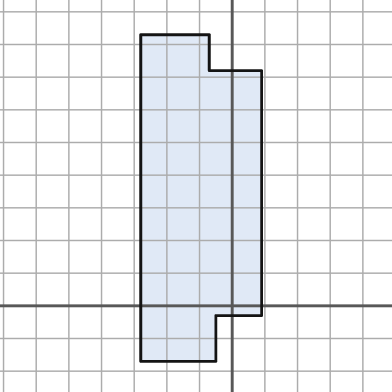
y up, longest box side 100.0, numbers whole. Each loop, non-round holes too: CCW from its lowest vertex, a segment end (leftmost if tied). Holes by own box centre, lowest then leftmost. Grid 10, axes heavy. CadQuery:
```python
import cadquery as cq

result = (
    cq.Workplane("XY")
    .moveTo(-28.0, -17.0)
    .lineTo(-5.0, -17.0)
    .lineTo(-5.0, -3.0)
    .lineTo(9.0, -3.0)
    .lineTo(9.0, 72.0)
    .lineTo(-7.0, 72.0)
    .lineTo(-7.0, 83.0)
    .lineTo(-28.0, 83.0)
    .close()
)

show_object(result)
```